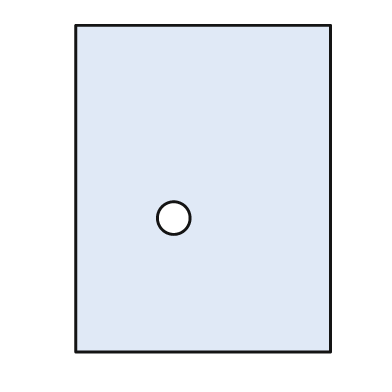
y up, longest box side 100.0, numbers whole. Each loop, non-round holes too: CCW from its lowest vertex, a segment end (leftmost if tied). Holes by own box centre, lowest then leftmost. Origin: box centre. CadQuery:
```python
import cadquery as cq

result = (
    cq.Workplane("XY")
    .moveTo(-39.0, -50.0)
    .lineTo(39.0, -50.0)
    .lineTo(39.0, 50.0)
    .lineTo(-39.0, 50.0)
    .close()
    .moveTo(-9.0, -9.0)
    .circle(5.0)
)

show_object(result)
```